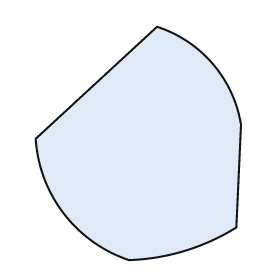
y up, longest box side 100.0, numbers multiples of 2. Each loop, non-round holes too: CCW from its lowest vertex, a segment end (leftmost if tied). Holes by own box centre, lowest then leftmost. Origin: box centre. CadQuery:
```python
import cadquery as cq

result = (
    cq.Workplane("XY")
    .moveTo(-4.0, -50.0)
    .threePointArc((20.0, -46.0), (42.0, -36.0))
    .lineTo(44.0, 8.0)
    .threePointArc((32.0, 34.0), (8.0, 50.0))
    .lineTo(-44.0, 2.0)
    .threePointArc((-32.0, -30.0), (-4.0, -50.0))
    .close()
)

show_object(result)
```